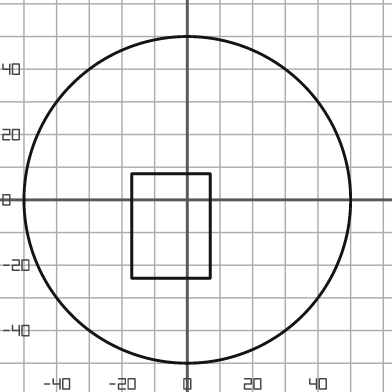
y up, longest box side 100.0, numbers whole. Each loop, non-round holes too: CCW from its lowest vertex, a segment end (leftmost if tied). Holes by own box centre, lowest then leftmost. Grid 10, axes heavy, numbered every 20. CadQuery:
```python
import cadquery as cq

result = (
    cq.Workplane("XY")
    .moveTo(0.0, 0.0)
    .circle(50.0)
    .moveTo(-17.0, -24.0)
    .lineTo(7.0, -24.0)
    .lineTo(7.0, 8.0)
    .lineTo(-17.0, 8.0)
    .close()
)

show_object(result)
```